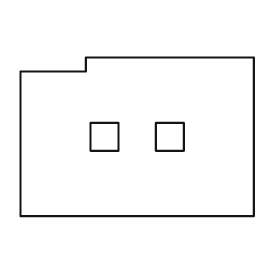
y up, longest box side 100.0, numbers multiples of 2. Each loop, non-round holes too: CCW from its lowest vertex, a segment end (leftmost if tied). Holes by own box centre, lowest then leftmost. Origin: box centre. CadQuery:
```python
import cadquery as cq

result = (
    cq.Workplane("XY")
    .moveTo(-50.0, -34.0)
    .lineTo(50.0, -34.0)
    .lineTo(50.0, 34.0)
    .lineTo(-22.0, 34.0)
    .lineTo(-22.0, 28.0)
    .lineTo(-50.0, 28.0)
    .close()
    .moveTo(-20.0, -6.0)
    .lineTo(-8.0, -6.0)
    .lineTo(-8.0, 6.0)
    .lineTo(-20.0, 6.0)
    .close()
    .moveTo(8.0, -6.0)
    .lineTo(20.0, -6.0)
    .lineTo(20.0, 6.0)
    .lineTo(8.0, 6.0)
    .close()
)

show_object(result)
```